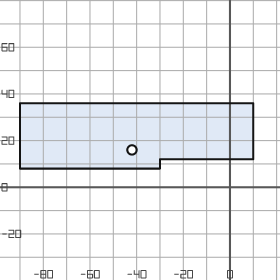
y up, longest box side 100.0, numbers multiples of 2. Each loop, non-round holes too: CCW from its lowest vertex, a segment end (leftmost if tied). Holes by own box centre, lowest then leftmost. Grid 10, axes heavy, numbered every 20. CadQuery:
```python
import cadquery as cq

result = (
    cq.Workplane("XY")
    .moveTo(-90.0, 8.0)
    .lineTo(-30.0, 8.0)
    .lineTo(-30.0, 12.0)
    .lineTo(10.0, 12.0)
    .lineTo(10.0, 36.0)
    .lineTo(-90.0, 36.0)
    .close()
    .moveTo(-42.0, 16.0)
    .circle(2.0)
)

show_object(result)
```